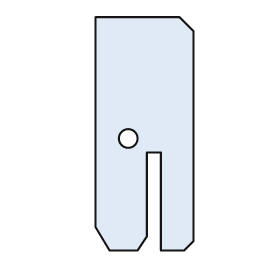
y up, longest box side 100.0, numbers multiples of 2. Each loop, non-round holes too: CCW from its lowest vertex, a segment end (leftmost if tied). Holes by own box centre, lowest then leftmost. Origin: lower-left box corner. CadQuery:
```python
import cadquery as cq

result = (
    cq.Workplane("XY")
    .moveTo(6.0, 0.0)
    .lineTo(18.0, 0.0)
    .lineTo(22.0, 6.0)
    .lineTo(22.0, 42.0)
    .lineTo(28.0, 42.0)
    .lineTo(28.0, 0.0)
    .lineTo(38.0, 0.0)
    .lineTo(42.0, 4.0)
    .lineTo(42.0, 94.0)
    .lineTo(36.0, 100.0)
    .lineTo(0.0, 100.0)
    .lineTo(0.0, 10.0)
    .close()
    .moveTo(14.0, 48.0)
    .circle(4.0)
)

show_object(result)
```